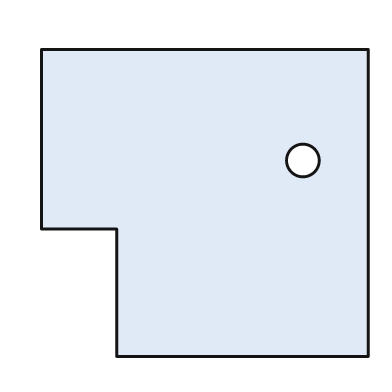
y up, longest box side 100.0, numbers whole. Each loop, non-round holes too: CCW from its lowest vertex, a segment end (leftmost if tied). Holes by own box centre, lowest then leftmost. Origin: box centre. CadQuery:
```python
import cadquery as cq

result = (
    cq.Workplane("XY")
    .moveTo(-27.0, -47.0)
    .lineTo(50.0, -47.0)
    .lineTo(50.0, 47.0)
    .lineTo(-50.0, 47.0)
    .lineTo(-50.0, -8.0)
    .lineTo(-27.0, -8.0)
    .close()
    .moveTo(30.0, 13.0)
    .circle(5.0)
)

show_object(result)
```